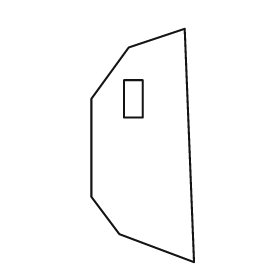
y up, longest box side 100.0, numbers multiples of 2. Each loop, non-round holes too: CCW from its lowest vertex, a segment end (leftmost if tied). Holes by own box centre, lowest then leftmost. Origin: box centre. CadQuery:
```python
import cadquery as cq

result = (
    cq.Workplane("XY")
    .moveTo(22.0, -50.0)
    .lineTo(18.0, 50.0)
    .lineTo(-6.0, 42.0)
    .lineTo(-22.0, 20.0)
    .lineTo(-22.0, -22.0)
    .lineTo(-10.0, -38.0)
    .close()
    .moveTo(-8.0, 12.0)
    .lineTo(0.0, 12.0)
    .lineTo(0.0, 28.0)
    .lineTo(-8.0, 28.0)
    .close()
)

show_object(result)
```